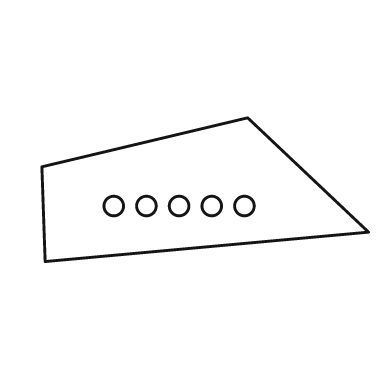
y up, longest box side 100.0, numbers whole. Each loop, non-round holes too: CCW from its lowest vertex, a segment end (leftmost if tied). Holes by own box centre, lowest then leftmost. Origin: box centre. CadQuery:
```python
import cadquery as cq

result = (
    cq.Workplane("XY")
    .moveTo(-49.0, -22.0)
    .lineTo(50.0, -13.0)
    .lineTo(13.0, 22.0)
    .lineTo(-50.0, 7.0)
    .close()
    .moveTo(-28.0, -5.0)
    .circle(3.0)
    .moveTo(-18.0, -5.0)
    .circle(3.0)
    .moveTo(-8.0, -5.0)
    .circle(3.0)
    .moveTo(2.0, -5.0)
    .circle(3.0)
    .moveTo(12.0, -5.0)
    .circle(3.0)
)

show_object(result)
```